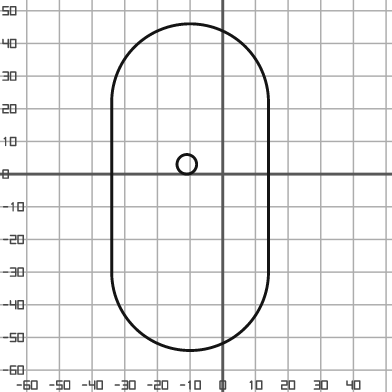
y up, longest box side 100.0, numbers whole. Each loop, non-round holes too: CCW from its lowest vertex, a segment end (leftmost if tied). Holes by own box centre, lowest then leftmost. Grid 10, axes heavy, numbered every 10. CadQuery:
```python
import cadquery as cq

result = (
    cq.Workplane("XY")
    .moveTo(-34.0, -30.0)
    .threePointArc((-10.0, -54.0), (14.0, -30.0))
    .lineTo(14.0, 22.0)
    .threePointArc((-10.0, 46.0), (-34.0, 22.0))
    .close()
    .moveTo(-11.0, 3.0)
    .circle(3.0)
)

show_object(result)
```